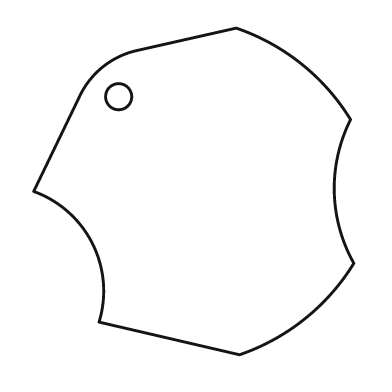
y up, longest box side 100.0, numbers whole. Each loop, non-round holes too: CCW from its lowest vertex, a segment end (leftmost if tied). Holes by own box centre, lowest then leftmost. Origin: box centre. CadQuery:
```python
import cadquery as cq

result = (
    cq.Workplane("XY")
    .moveTo(14.0, -50.0)
    .threePointArc((34.0, -39.0), (49.0, -22.0))
    .threePointArc((43.0, 0.0), (48.0, 22.0))
    .threePointArc((33.0, 39.0), (13.0, 50.0))
    .lineTo(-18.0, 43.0)
    .threePointArc((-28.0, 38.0), (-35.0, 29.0))
    .lineTo(-49.0, 0.0)
    .threePointArc((-31.0, -16.0), (-29.0, -40.0))
    .close()
    .moveTo(-23.0, 29.0)
    .circle(4.0)
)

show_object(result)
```